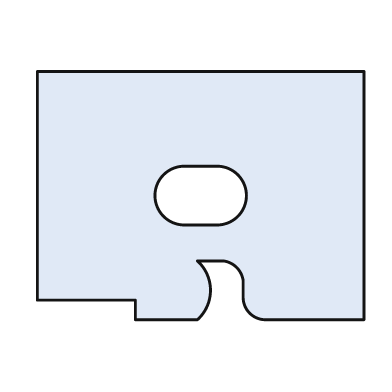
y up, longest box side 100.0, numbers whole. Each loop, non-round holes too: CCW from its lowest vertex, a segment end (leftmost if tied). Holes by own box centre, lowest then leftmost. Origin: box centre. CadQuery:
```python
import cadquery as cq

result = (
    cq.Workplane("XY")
    .moveTo(-20.0, -38.0)
    .lineTo(-1.0, -38.0)
    .threePointArc((3.0, -29.0), (-1.0, -20.0))
    .lineTo(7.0, -20.0)
    .threePointArc((11.0, -22.0), (13.0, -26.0))
    .lineTo(13.0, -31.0)
    .threePointArc((15.0, -36.0), (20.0, -38.0))
    .lineTo(50.0, -38.0)
    .lineTo(50.0, 38.0)
    .lineTo(-50.0, 38.0)
    .lineTo(-50.0, -32.0)
    .lineTo(-20.0, -32.0)
    .close()
    .moveTo(-5.0, -9.0)
    .lineTo(5.0, -9.0)
    .threePointArc((14.0, 0.0), (5.0, 9.0))
    .lineTo(-5.0, 9.0)
    .threePointArc((-14.0, 0.0), (-5.0, -9.0))
    .close()
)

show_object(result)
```